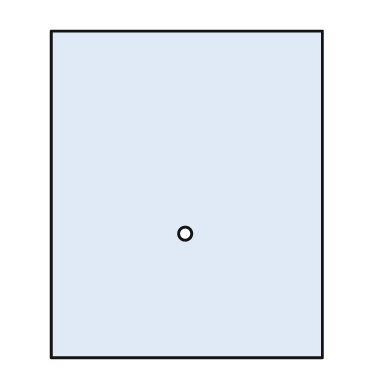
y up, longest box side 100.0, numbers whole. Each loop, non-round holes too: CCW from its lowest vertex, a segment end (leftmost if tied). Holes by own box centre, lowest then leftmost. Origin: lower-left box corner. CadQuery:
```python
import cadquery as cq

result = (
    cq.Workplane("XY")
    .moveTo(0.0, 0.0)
    .lineTo(83.0, 0.0)
    .lineTo(83.0, 100.0)
    .lineTo(0.0, 100.0)
    .close()
    .moveTo(41.0, 38.0)
    .circle(2.0)
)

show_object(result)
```